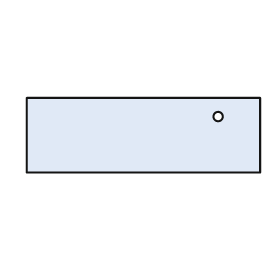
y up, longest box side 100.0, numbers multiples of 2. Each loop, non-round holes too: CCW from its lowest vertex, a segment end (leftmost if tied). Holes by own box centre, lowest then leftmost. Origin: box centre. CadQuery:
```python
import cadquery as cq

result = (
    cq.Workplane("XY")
    .moveTo(-50.0, -16.0)
    .lineTo(50.0, -16.0)
    .lineTo(50.0, 16.0)
    .lineTo(-50.0, 16.0)
    .close()
    .moveTo(32.0, 8.0)
    .circle(2.0)
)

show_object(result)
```